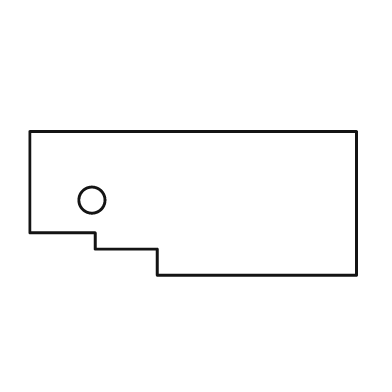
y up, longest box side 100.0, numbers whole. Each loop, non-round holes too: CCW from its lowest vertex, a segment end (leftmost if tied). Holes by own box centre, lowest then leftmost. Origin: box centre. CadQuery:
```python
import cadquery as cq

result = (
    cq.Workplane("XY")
    .moveTo(-11.0, -22.0)
    .lineTo(50.0, -22.0)
    .lineTo(50.0, 22.0)
    .lineTo(-50.0, 22.0)
    .lineTo(-50.0, -9.0)
    .lineTo(-30.0, -9.0)
    .lineTo(-30.0, -14.0)
    .lineTo(-11.0, -14.0)
    .close()
    .moveTo(-31.0, 1.0)
    .circle(4.0)
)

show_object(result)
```